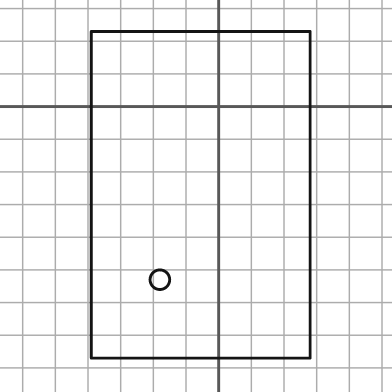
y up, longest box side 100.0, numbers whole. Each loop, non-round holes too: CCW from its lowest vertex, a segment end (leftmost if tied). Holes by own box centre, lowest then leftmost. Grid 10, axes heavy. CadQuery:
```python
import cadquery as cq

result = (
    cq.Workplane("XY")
    .moveTo(-39.0, -77.0)
    .lineTo(28.0, -77.0)
    .lineTo(28.0, 23.0)
    .lineTo(-39.0, 23.0)
    .close()
    .moveTo(-18.0, -53.0)
    .circle(3.0)
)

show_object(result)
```